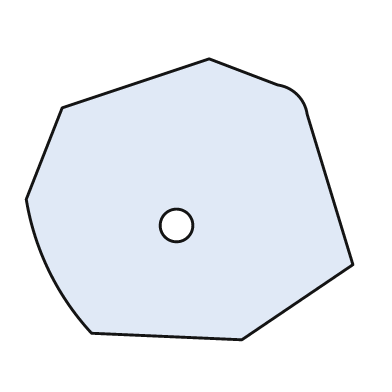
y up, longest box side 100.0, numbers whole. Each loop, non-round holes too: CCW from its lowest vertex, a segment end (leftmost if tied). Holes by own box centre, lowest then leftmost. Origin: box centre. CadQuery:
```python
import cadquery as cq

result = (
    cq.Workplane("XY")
    .moveTo(16.0, -43.0)
    .lineTo(50.0, -20.0)
    .lineTo(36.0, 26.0)
    .threePointArc((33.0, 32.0), (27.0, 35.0))
    .lineTo(6.0, 43.0)
    .lineTo(-39.0, 28.0)
    .lineTo(-50.0, 0.0)
    .threePointArc((-43.0, -22.0), (-30.0, -41.0))
    .close()
    .moveTo(-4.0, -8.0)
    .circle(5.0)
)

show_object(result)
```